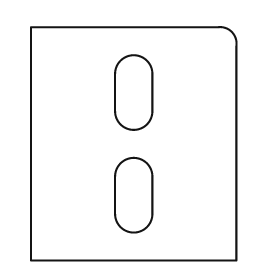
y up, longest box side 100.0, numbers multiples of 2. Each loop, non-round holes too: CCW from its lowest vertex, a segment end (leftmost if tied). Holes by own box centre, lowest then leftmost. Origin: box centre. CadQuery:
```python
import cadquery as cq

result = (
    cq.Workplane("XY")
    .moveTo(-44.0, -50.0)
    .lineTo(44.0, -50.0)
    .lineTo(44.0, 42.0)
    .threePointArc((42.0, 48.0), (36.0, 50.0))
    .lineTo(-44.0, 50.0)
    .close()
    .moveTo(-8.0, -30.0)
    .threePointArc((0.0, -38.0), (8.0, -30.0))
    .lineTo(8.0, -14.0)
    .threePointArc((0.0, -6.0), (-8.0, -14.0))
    .close()
    .moveTo(-8.0, 14.0)
    .threePointArc((0.0, 6.0), (8.0, 14.0))
    .lineTo(8.0, 30.0)
    .threePointArc((0.0, 38.0), (-8.0, 30.0))
    .close()
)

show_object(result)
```